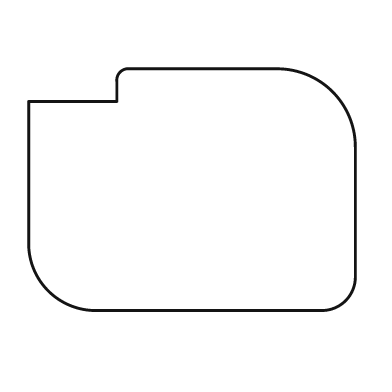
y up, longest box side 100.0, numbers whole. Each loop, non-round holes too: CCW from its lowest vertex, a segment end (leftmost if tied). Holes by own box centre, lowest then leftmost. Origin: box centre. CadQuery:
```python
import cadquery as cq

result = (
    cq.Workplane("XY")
    .moveTo(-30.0, -37.0)
    .lineTo(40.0, -37.0)
    .threePointArc((47.0, -34.0), (50.0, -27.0))
    .lineTo(50.0, 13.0)
    .threePointArc((43.0, 30.0), (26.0, 37.0))
    .lineTo(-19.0, 37.0)
    .threePointArc((-22.0, 36.0), (-23.0, 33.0))
    .lineTo(-23.0, 27.0)
    .lineTo(-50.0, 27.0)
    .lineTo(-50.0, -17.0)
    .threePointArc((-44.0, -31.0), (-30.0, -37.0))
    .close()
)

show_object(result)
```